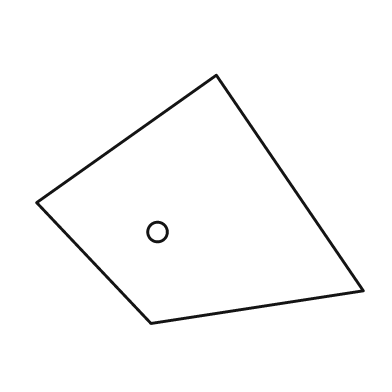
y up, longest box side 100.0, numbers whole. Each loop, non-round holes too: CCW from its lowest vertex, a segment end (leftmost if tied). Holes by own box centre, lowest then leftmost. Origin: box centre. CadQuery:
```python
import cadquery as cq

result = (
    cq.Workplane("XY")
    .moveTo(-15.0, -38.0)
    .lineTo(50.0, -28.0)
    .lineTo(5.0, 38.0)
    .lineTo(-50.0, -1.0)
    .close()
    .moveTo(-13.0, -10.0)
    .circle(3.0)
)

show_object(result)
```